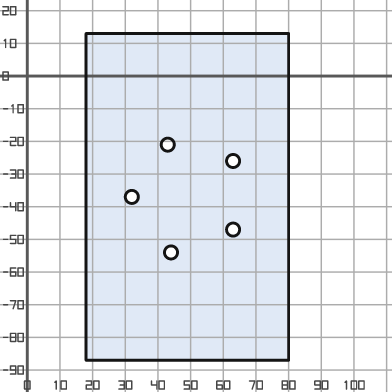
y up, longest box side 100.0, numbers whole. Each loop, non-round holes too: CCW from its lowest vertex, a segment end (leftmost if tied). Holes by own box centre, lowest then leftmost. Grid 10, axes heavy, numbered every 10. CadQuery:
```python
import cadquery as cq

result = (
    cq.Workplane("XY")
    .moveTo(18.0, -87.0)
    .lineTo(80.0, -87.0)
    .lineTo(80.0, 13.0)
    .lineTo(18.0, 13.0)
    .close()
    .moveTo(44.0, -54.0)
    .circle(2.0)
    .moveTo(63.0, -47.0)
    .circle(2.0)
    .moveTo(32.0, -37.0)
    .circle(2.0)
    .moveTo(63.0, -26.0)
    .circle(2.0)
    .moveTo(43.0, -21.0)
    .circle(2.0)
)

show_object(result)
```